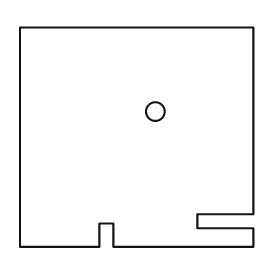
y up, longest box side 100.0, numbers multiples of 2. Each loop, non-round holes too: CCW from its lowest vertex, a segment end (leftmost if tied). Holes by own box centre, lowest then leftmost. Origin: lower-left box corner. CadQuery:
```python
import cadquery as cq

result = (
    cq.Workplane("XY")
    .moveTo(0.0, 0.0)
    .lineTo(34.0, 0.0)
    .lineTo(34.0, 10.0)
    .lineTo(40.0, 10.0)
    .lineTo(40.0, 0.0)
    .lineTo(100.0, 0.0)
    .lineTo(100.0, 8.0)
    .lineTo(76.0, 8.0)
    .lineTo(76.0, 14.0)
    .lineTo(100.0, 14.0)
    .lineTo(100.0, 94.0)
    .lineTo(0.0, 94.0)
    .close()
    .moveTo(58.0, 58.0)
    .circle(4.0)
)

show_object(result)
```